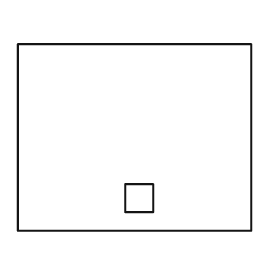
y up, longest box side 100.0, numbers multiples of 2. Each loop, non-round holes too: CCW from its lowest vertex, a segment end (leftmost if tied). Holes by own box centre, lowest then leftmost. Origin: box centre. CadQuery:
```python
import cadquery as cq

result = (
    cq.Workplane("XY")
    .moveTo(-50.0, -40.0)
    .lineTo(50.0, -40.0)
    .lineTo(50.0, 40.0)
    .lineTo(-50.0, 40.0)
    .close()
    .moveTo(-4.0, -32.0)
    .lineTo(8.0, -32.0)
    .lineTo(8.0, -20.0)
    .lineTo(-4.0, -20.0)
    .close()
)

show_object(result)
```